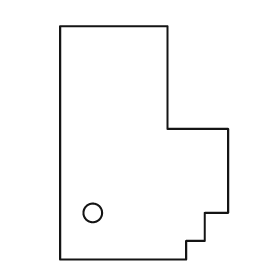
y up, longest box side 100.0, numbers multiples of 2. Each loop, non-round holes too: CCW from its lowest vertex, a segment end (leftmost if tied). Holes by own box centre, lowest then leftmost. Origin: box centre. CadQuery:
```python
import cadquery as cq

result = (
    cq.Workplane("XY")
    .moveTo(-36.0, -50.0)
    .lineTo(18.0, -50.0)
    .lineTo(18.0, -42.0)
    .lineTo(26.0, -42.0)
    .lineTo(26.0, -30.0)
    .lineTo(36.0, -30.0)
    .lineTo(36.0, 6.0)
    .lineTo(10.0, 6.0)
    .lineTo(10.0, 50.0)
    .lineTo(-36.0, 50.0)
    .close()
    .moveTo(-22.0, -30.0)
    .circle(4.0)
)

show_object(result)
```